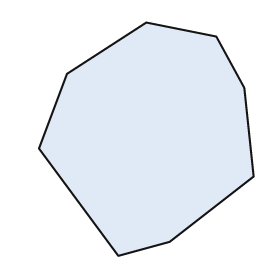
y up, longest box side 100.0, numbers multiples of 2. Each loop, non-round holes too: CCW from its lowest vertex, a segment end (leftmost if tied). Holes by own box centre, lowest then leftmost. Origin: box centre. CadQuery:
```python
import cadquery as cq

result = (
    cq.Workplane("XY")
    .moveTo(-12.0, -50.0)
    .lineTo(10.0, -44.0)
    .lineTo(46.0, -16.0)
    .lineTo(42.0, 22.0)
    .lineTo(30.0, 44.0)
    .lineTo(0.0, 50.0)
    .lineTo(-34.0, 28.0)
    .lineTo(-46.0, -4.0)
    .close()
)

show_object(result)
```